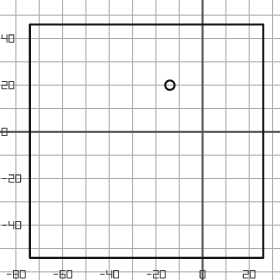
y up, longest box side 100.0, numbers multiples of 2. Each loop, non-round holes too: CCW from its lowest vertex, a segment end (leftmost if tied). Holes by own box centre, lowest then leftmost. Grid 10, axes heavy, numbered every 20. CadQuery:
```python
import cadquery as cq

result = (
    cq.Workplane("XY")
    .moveTo(-74.0, -54.0)
    .lineTo(26.0, -54.0)
    .lineTo(26.0, 46.0)
    .lineTo(-74.0, 46.0)
    .close()
    .moveTo(-14.0, 20.0)
    .circle(2.0)
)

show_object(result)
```